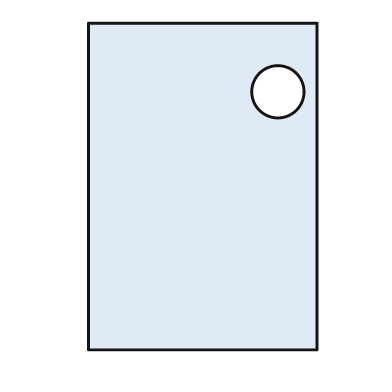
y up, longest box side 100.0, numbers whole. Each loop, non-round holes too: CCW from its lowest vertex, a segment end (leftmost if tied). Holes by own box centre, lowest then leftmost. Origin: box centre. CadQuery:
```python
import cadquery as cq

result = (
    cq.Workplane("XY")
    .moveTo(-35.0, -50.0)
    .lineTo(35.0, -50.0)
    .lineTo(35.0, 50.0)
    .lineTo(-35.0, 50.0)
    .close()
    .moveTo(23.0, 29.0)
    .circle(8.0)
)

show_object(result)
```